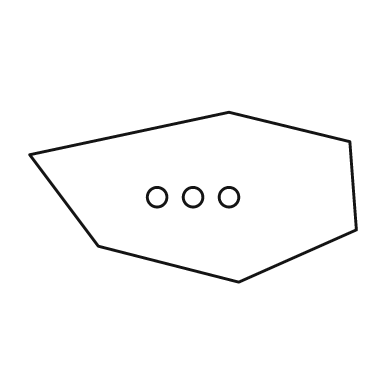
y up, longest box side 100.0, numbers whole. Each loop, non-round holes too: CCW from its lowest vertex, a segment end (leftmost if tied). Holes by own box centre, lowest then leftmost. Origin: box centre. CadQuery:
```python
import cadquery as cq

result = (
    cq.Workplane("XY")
    .moveTo(14.0, -26.0)
    .lineTo(50.0, -10.0)
    .lineTo(48.0, 17.0)
    .lineTo(11.0, 26.0)
    .lineTo(-50.0, 13.0)
    .lineTo(-29.0, -15.0)
    .close()
    .moveTo(-11.0, 0.0)
    .circle(3.0)
    .moveTo(0.0, 0.0)
    .circle(3.0)
    .moveTo(11.0, 0.0)
    .circle(3.0)
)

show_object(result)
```